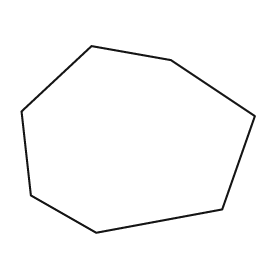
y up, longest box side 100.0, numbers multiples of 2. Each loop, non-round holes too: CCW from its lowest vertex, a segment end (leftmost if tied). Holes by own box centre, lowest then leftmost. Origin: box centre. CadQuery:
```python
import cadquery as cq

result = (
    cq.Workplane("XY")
    .moveTo(-18.0, -40.0)
    .lineTo(36.0, -30.0)
    .lineTo(50.0, 10.0)
    .lineTo(14.0, 34.0)
    .lineTo(-20.0, 40.0)
    .lineTo(-50.0, 12.0)
    .lineTo(-46.0, -24.0)
    .close()
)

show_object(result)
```